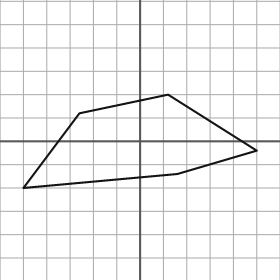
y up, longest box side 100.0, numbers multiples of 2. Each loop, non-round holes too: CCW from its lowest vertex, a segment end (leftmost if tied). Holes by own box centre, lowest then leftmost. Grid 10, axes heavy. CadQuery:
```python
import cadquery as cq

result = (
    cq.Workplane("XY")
    .moveTo(-50.0, -20.0)
    .lineTo(16.0, -14.0)
    .lineTo(50.0, -4.0)
    .lineTo(12.0, 20.0)
    .lineTo(-26.0, 12.0)
    .close()
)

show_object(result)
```